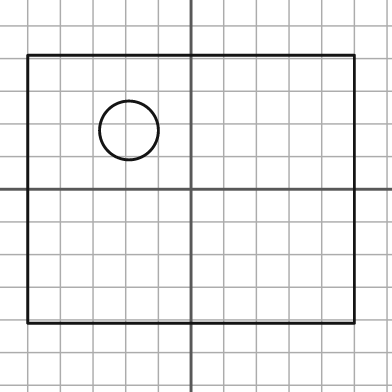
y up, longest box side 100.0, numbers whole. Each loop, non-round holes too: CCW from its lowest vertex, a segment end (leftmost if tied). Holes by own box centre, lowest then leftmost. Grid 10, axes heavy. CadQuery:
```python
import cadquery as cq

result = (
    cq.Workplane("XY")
    .moveTo(-50.0, -41.0)
    .lineTo(50.0, -41.0)
    .lineTo(50.0, 41.0)
    .lineTo(-50.0, 41.0)
    .close()
    .moveTo(-19.0, 18.0)
    .circle(9.0)
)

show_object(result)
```